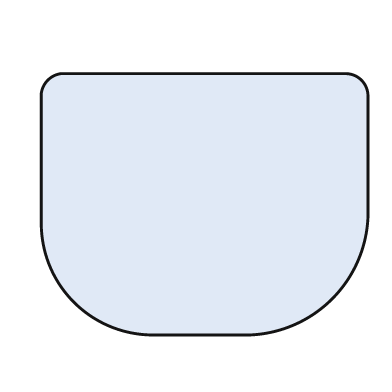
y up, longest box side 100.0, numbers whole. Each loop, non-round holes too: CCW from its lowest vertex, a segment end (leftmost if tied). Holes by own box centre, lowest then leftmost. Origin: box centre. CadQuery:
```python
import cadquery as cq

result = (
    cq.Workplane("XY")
    .moveTo(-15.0, -40.0)
    .lineTo(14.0, -40.0)
    .threePointArc((39.0, -29.0), (50.0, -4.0))
    .lineTo(50.0, 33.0)
    .threePointArc((48.0, 38.0), (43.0, 40.0))
    .lineTo(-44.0, 40.0)
    .threePointArc((-48.0, 38.0), (-50.0, 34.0))
    .lineTo(-50.0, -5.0)
    .threePointArc((-40.0, -30.0), (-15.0, -40.0))
    .close()
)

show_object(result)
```